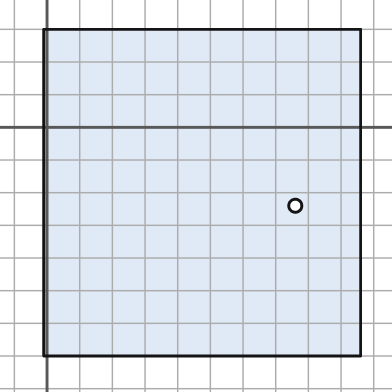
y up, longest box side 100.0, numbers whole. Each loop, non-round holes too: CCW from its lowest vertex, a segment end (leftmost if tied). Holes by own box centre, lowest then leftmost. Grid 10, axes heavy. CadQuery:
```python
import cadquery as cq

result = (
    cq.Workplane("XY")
    .moveTo(-1.0, -70.0)
    .lineTo(96.0, -70.0)
    .lineTo(96.0, 30.0)
    .lineTo(-1.0, 30.0)
    .close()
    .moveTo(76.0, -24.0)
    .circle(2.0)
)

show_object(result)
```